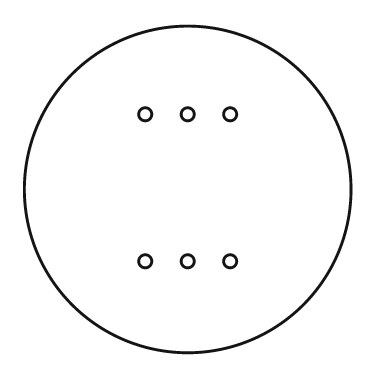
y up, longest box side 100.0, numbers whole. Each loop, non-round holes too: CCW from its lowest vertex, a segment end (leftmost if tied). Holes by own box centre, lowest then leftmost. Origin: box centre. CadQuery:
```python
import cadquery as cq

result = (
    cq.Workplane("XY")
    .moveTo(0.0, 0.0)
    .circle(50.0)
    .moveTo(-13.0, -22.0)
    .circle(2.0)
    .moveTo(0.0, -22.0)
    .circle(2.0)
    .moveTo(13.0, -22.0)
    .circle(2.0)
    .moveTo(-13.0, 23.0)
    .circle(2.0)
    .moveTo(0.0, 23.0)
    .circle(2.0)
    .moveTo(13.0, 23.0)
    .circle(2.0)
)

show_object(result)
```